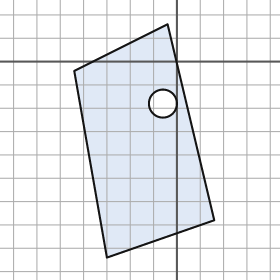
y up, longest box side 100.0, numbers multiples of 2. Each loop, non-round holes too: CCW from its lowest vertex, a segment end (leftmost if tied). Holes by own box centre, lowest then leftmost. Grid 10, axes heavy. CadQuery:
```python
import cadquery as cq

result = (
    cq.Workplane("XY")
    .moveTo(-30.0, -84.0)
    .lineTo(16.0, -68.0)
    .lineTo(-4.0, 16.0)
    .lineTo(-44.0, -4.0)
    .close()
    .moveTo(-6.0, -18.0)
    .circle(6.0)
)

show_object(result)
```